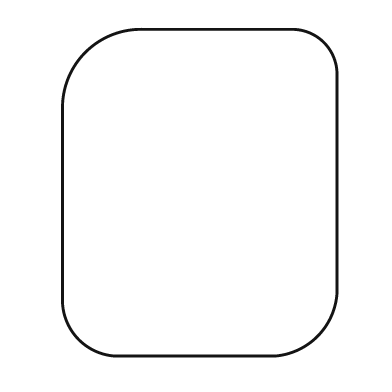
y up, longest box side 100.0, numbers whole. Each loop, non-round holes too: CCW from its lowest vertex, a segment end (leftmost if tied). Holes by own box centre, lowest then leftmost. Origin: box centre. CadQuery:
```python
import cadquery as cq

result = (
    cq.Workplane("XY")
    .moveTo(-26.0, -50.0)
    .lineTo(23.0, -50.0)
    .threePointArc((36.0, -44.0), (42.0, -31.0))
    .lineTo(42.0, 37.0)
    .threePointArc((38.0, 46.0), (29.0, 50.0))
    .lineTo(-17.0, 50.0)
    .threePointArc((-35.0, 43.0), (-42.0, 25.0))
    .lineTo(-42.0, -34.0)
    .threePointArc((-37.0, -45.0), (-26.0, -50.0))
    .close()
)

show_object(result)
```